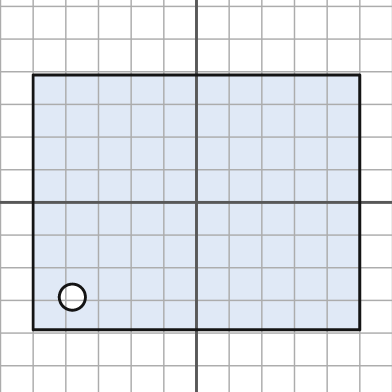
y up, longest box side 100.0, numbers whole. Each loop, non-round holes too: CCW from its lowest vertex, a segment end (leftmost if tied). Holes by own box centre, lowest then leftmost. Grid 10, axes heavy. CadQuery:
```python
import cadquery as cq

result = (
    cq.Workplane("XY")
    .moveTo(-50.0, -39.0)
    .lineTo(50.0, -39.0)
    .lineTo(50.0, 39.0)
    .lineTo(-50.0, 39.0)
    .close()
    .moveTo(-38.0, -29.0)
    .circle(4.0)
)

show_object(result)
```